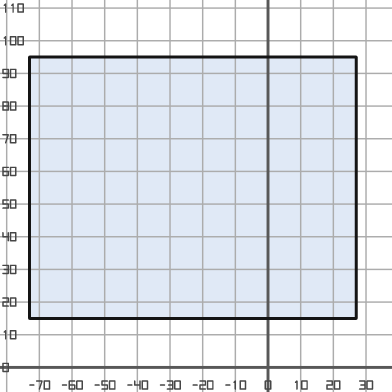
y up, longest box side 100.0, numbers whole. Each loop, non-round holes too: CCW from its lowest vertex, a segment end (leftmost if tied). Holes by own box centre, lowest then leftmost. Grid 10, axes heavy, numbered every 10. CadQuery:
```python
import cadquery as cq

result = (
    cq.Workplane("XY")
    .moveTo(-73.0, 15.0)
    .lineTo(27.0, 15.0)
    .lineTo(27.0, 95.0)
    .lineTo(-73.0, 95.0)
    .close()
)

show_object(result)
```